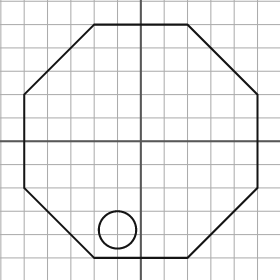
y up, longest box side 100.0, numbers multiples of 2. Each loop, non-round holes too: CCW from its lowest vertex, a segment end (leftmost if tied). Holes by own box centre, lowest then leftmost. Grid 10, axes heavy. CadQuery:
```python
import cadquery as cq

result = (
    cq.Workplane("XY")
    .moveTo(-20.0, -50.0)
    .lineTo(20.0, -50.0)
    .lineTo(50.0, -20.0)
    .lineTo(50.0, 20.0)
    .lineTo(20.0, 50.0)
    .lineTo(-20.0, 50.0)
    .lineTo(-50.0, 20.0)
    .lineTo(-50.0, -20.0)
    .close()
    .moveTo(-10.0, -38.0)
    .circle(8.0)
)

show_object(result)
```